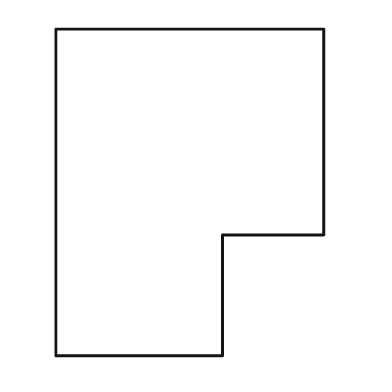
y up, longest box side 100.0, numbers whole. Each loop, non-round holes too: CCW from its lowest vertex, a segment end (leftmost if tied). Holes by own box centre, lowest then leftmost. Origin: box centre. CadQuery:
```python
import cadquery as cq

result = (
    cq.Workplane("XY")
    .moveTo(-41.0, -50.0)
    .lineTo(10.0, -50.0)
    .lineTo(10.0, -13.0)
    .lineTo(41.0, -13.0)
    .lineTo(41.0, 50.0)
    .lineTo(-41.0, 50.0)
    .close()
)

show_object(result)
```